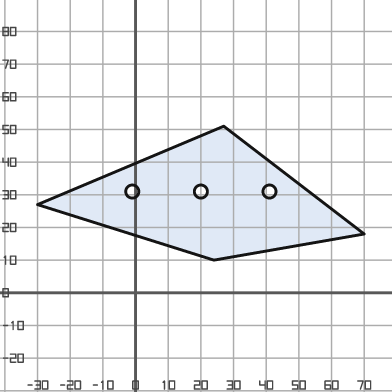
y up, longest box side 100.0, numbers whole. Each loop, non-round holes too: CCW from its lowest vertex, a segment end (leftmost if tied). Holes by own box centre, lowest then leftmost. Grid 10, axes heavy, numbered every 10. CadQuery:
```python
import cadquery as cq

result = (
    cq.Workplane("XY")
    .moveTo(24.0, 10.0)
    .lineTo(70.0, 18.0)
    .lineTo(27.0, 51.0)
    .lineTo(-30.0, 27.0)
    .close()
    .moveTo(-1.0, 31.0)
    .circle(2.0)
    .moveTo(20.0, 31.0)
    .circle(2.0)
    .moveTo(41.0, 31.0)
    .circle(2.0)
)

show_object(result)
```